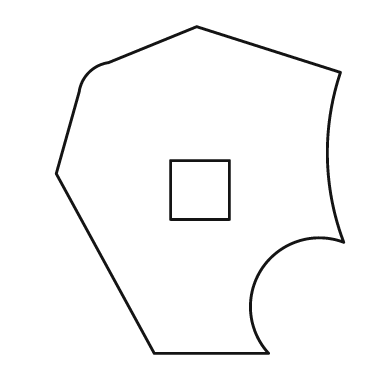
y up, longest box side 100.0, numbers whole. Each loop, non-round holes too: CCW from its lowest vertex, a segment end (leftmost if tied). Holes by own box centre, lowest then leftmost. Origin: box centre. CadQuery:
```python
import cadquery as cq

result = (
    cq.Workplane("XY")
    .moveTo(-14.0, -50.0)
    .lineTo(21.0, -50.0)
    .threePointArc((19.0, -24.0), (44.0, -16.0))
    .threePointArc((39.0, 10.0), (43.0, 36.0))
    .lineTo(-1.0, 50.0)
    .lineTo(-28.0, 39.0)
    .threePointArc((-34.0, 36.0), (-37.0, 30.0))
    .lineTo(-44.0, 5.0)
    .close()
    .moveTo(-9.0, -9.0)
    .lineTo(9.0, -9.0)
    .lineTo(9.0, 9.0)
    .lineTo(-9.0, 9.0)
    .close()
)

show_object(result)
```